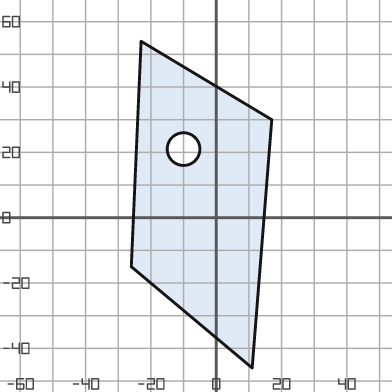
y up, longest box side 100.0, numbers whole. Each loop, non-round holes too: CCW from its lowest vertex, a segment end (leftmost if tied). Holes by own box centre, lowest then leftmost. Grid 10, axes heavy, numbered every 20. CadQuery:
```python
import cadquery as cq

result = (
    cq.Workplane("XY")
    .moveTo(11.0, -46.0)
    .lineTo(17.0, 30.0)
    .lineTo(-23.0, 54.0)
    .lineTo(-26.0, -15.0)
    .close()
    .moveTo(-10.0, 21.0)
    .circle(5.0)
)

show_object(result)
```